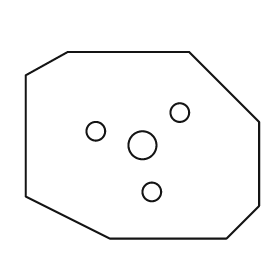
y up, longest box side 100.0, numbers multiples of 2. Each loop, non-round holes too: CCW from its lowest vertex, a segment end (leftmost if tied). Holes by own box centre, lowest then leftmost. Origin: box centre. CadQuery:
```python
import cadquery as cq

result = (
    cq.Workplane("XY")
    .moveTo(-14.0, -40.0)
    .lineTo(36.0, -40.0)
    .lineTo(50.0, -26.0)
    .lineTo(50.0, 10.0)
    .lineTo(20.0, 40.0)
    .lineTo(-32.0, 40.0)
    .lineTo(-50.0, 30.0)
    .lineTo(-50.0, -22.0)
    .close()
    .moveTo(4.0, -20.0)
    .circle(4.0)
    .moveTo(0.0, 0.0)
    .circle(6.0)
    .moveTo(-20.0, 6.0)
    .circle(4.0)
    .moveTo(16.0, 14.0)
    .circle(4.0)
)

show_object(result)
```